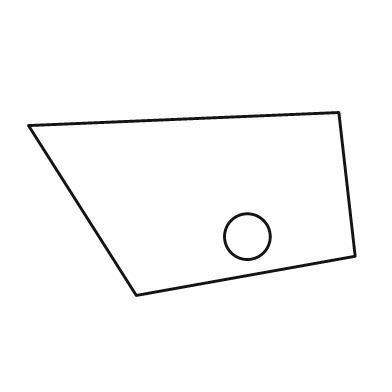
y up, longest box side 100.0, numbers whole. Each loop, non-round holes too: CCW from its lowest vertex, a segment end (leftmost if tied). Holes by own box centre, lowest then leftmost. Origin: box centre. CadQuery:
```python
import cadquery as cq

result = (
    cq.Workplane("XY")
    .moveTo(-17.0, -28.0)
    .lineTo(50.0, -16.0)
    .lineTo(45.0, 28.0)
    .lineTo(-50.0, 24.0)
    .close()
    .moveTo(17.0, -10.0)
    .circle(7.0)
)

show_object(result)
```